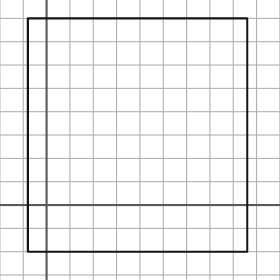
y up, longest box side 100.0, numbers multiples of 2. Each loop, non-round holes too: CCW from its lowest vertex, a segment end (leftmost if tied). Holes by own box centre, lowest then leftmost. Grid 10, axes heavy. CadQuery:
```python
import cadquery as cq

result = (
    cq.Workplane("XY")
    .moveTo(-8.0, -20.0)
    .lineTo(86.0, -20.0)
    .lineTo(86.0, 80.0)
    .lineTo(-8.0, 80.0)
    .close()
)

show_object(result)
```